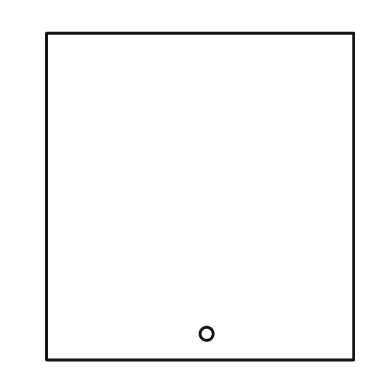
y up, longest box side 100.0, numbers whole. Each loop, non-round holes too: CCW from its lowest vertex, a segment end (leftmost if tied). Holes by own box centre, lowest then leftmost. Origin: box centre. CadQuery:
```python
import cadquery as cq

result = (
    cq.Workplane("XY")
    .moveTo(-47.0, -50.0)
    .lineTo(47.0, -50.0)
    .lineTo(47.0, 50.0)
    .lineTo(-47.0, 50.0)
    .close()
    .moveTo(2.0, -42.0)
    .circle(2.0)
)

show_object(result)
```